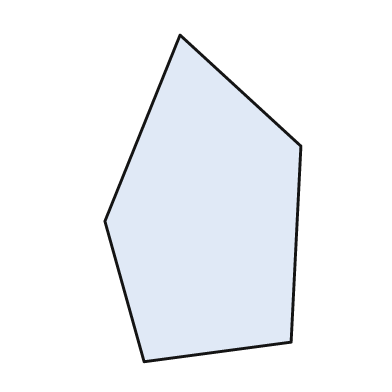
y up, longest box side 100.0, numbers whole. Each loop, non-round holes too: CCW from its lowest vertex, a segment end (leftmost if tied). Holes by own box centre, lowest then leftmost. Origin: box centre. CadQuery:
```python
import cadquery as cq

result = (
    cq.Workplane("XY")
    .moveTo(-18.0, -50.0)
    .lineTo(27.0, -44.0)
    .lineTo(30.0, 16.0)
    .lineTo(-7.0, 50.0)
    .lineTo(-30.0, -7.0)
    .close()
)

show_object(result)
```